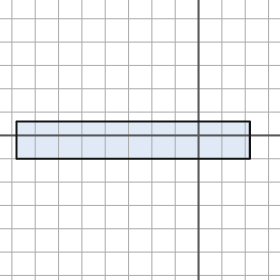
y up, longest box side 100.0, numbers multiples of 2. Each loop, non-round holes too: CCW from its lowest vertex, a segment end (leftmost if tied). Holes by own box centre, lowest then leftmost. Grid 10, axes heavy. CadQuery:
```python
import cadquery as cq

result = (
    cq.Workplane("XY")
    .moveTo(-78.0, -10.0)
    .lineTo(22.0, -10.0)
    .lineTo(22.0, 6.0)
    .lineTo(-78.0, 6.0)
    .close()
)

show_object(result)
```